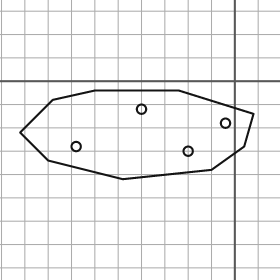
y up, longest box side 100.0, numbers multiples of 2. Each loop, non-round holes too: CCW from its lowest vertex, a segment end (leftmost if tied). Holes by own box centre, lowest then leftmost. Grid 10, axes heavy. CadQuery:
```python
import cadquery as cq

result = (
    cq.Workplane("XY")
    .moveTo(-48.0, -42.0)
    .lineTo(-10.0, -38.0)
    .lineTo(4.0, -28.0)
    .lineTo(8.0, -14.0)
    .lineTo(-24.0, -4.0)
    .lineTo(-60.0, -4.0)
    .lineTo(-78.0, -8.0)
    .lineTo(-92.0, -22.0)
    .lineTo(-80.0, -34.0)
    .close()
    .moveTo(-20.0, -30.0)
    .circle(2.0)
    .moveTo(-68.0, -28.0)
    .circle(2.0)
    .moveTo(-4.0, -18.0)
    .circle(2.0)
    .moveTo(-40.0, -12.0)
    .circle(2.0)
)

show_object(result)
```